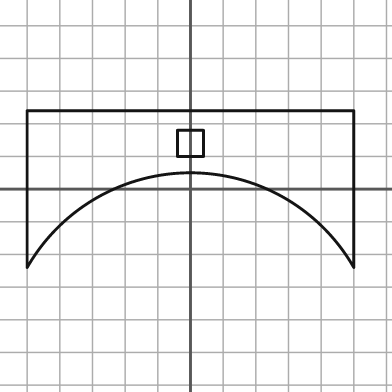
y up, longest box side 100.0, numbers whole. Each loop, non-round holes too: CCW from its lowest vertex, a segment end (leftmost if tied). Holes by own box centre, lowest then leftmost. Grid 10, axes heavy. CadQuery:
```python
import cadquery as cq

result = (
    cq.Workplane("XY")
    .moveTo(-50.0, -24.0)
    .threePointArc((0.0, 5.0), (50.0, -24.0))
    .lineTo(50.0, 24.0)
    .lineTo(-50.0, 24.0)
    .close()
    .moveTo(-4.0, 10.0)
    .lineTo(4.0, 10.0)
    .lineTo(4.0, 18.0)
    .lineTo(-4.0, 18.0)
    .close()
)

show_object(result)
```